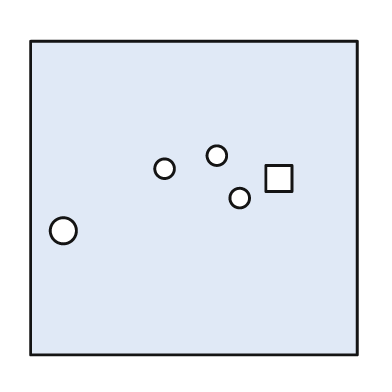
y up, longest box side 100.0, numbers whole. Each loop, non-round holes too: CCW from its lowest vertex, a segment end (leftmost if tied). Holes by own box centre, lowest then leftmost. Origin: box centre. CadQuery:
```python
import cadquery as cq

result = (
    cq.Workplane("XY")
    .moveTo(-50.0, -48.0)
    .lineTo(50.0, -48.0)
    .lineTo(50.0, 48.0)
    .lineTo(-50.0, 48.0)
    .close()
    .moveTo(-40.0, -10.0)
    .circle(4.0)
    .moveTo(14.0, 0.0)
    .circle(3.0)
    .moveTo(22.0, 2.0)
    .lineTo(30.0, 2.0)
    .lineTo(30.0, 10.0)
    .lineTo(22.0, 10.0)
    .close()
    .moveTo(-9.0, 9.0)
    .circle(3.0)
    .moveTo(7.0, 13.0)
    .circle(3.0)
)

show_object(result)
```